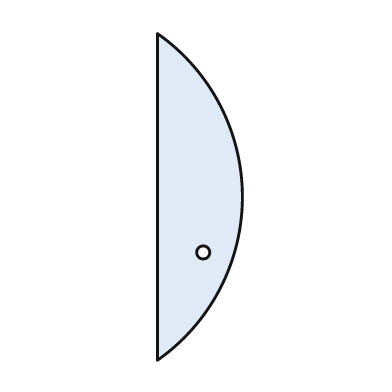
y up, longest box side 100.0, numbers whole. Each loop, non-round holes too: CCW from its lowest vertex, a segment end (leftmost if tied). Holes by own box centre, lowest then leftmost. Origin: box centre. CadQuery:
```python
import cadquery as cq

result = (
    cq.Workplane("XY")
    .moveTo(-13.0, -50.0)
    .threePointArc((13.0, 0.0), (-13.0, 50.0))
    .close()
    .moveTo(1.0, -17.0)
    .circle(2.0)
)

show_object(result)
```